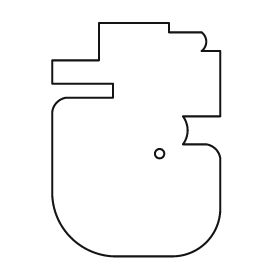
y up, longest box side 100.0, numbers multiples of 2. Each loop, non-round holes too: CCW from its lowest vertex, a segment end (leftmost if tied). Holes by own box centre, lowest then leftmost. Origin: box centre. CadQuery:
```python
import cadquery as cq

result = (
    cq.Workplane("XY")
    .moveTo(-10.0, -50.0)
    .lineTo(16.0, -50.0)
    .threePointArc((30.0, -44.0), (36.0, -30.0))
    .lineTo(36.0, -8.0)
    .threePointArc((34.0, -4.0), (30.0, -2.0))
    .lineTo(20.0, -2.0)
    .threePointArc((22.0, 4.0), (20.0, 10.0))
    .lineTo(36.0, 10.0)
    .lineTo(36.0, 38.0)
    .lineTo(28.0, 38.0)
    .threePointArc((30.0, 42.0), (28.0, 46.0))
    .lineTo(14.0, 46.0)
    .lineTo(14.0, 50.0)
    .lineTo(-16.0, 50.0)
    .lineTo(-16.0, 34.0)
    .lineTo(-36.0, 34.0)
    .lineTo(-36.0, 24.0)
    .lineTo(-10.0, 24.0)
    .lineTo(-10.0, 18.0)
    .lineTo(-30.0, 18.0)
    .threePointArc((-34.0, 16.0), (-36.0, 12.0))
    .lineTo(-36.0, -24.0)
    .threePointArc((-28.0, -42.0), (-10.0, -50.0))
    .close()
    .moveTo(10.0, -6.0)
    .circle(2.0)
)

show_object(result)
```